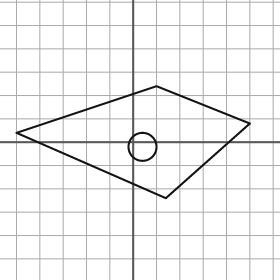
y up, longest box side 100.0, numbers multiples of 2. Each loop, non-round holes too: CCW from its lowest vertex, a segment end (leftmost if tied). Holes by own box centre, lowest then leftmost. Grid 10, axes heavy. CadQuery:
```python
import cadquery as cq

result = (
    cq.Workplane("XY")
    .moveTo(14.0, -24.0)
    .lineTo(50.0, 8.0)
    .lineTo(10.0, 24.0)
    .lineTo(-50.0, 4.0)
    .close()
    .moveTo(4.0, -2.0)
    .circle(6.0)
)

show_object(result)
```